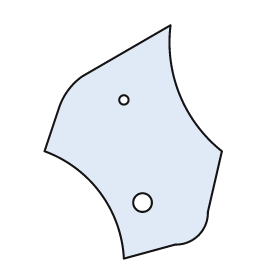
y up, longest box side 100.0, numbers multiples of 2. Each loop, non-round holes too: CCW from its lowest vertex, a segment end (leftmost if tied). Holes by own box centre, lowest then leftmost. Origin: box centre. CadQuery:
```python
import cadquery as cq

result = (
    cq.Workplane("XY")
    .moveTo(-4.0, -50.0)
    .lineTo(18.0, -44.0)
    .threePointArc((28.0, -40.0), (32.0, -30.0))
    .lineTo(38.0, -4.0)
    .threePointArc((20.0, 20.0), (16.0, 50.0))
    .lineTo(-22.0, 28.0)
    .threePointArc((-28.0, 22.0), (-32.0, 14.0))
    .lineTo(-38.0, -4.0)
    .threePointArc((-14.0, -22.0), (-4.0, -50.0))
    .close()
    .moveTo(4.0, -26.0)
    .circle(4.0)
    .moveTo(-4.0, 18.0)
    .circle(2.0)
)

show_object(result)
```